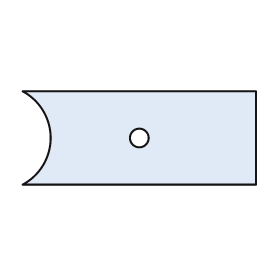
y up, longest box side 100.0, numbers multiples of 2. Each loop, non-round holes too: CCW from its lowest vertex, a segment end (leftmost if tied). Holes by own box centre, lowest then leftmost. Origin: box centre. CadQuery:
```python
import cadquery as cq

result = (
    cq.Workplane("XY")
    .moveTo(-50.0, -20.0)
    .lineTo(50.0, -20.0)
    .lineTo(50.0, 20.0)
    .lineTo(-50.0, 20.0)
    .threePointArc((-38.0, 0.0), (-50.0, -20.0))
    .close()
    .moveTo(0.0, 0.0)
    .circle(4.0)
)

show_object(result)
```